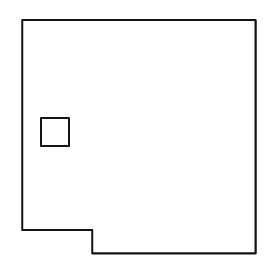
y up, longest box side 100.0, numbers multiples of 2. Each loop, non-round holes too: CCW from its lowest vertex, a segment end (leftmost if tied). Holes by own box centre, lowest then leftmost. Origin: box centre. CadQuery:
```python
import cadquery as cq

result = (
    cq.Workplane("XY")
    .moveTo(-20.0, -50.0)
    .lineTo(50.0, -50.0)
    .lineTo(50.0, 50.0)
    .lineTo(-50.0, 50.0)
    .lineTo(-50.0, -40.0)
    .lineTo(-20.0, -40.0)
    .close()
    .moveTo(-42.0, -4.0)
    .lineTo(-30.0, -4.0)
    .lineTo(-30.0, 8.0)
    .lineTo(-42.0, 8.0)
    .close()
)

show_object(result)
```